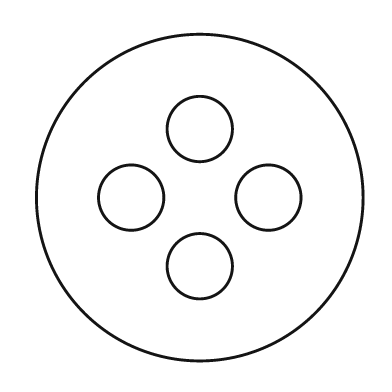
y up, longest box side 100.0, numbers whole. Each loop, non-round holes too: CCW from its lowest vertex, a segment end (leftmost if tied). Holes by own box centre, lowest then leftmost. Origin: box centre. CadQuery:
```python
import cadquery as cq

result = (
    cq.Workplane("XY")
    .moveTo(0.0, 0.0)
    .circle(50.0)
    .moveTo(0.0, -21.0)
    .circle(10.0)
    .moveTo(-21.0, 0.0)
    .circle(10.0)
    .moveTo(21.0, 0.0)
    .circle(10.0)
    .moveTo(0.0, 21.0)
    .circle(10.0)
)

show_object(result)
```